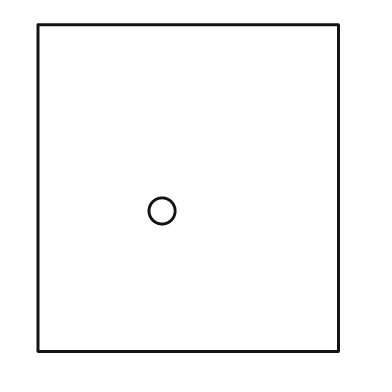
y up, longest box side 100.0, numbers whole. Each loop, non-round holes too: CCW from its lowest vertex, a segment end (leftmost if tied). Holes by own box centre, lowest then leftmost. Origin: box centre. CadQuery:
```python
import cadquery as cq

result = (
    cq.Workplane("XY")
    .moveTo(-46.0, -50.0)
    .lineTo(46.0, -50.0)
    .lineTo(46.0, 50.0)
    .lineTo(-46.0, 50.0)
    .close()
    .moveTo(-8.0, -7.0)
    .circle(4.0)
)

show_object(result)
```